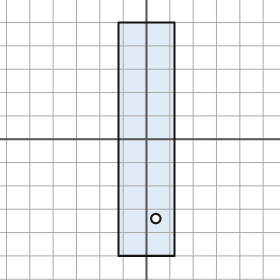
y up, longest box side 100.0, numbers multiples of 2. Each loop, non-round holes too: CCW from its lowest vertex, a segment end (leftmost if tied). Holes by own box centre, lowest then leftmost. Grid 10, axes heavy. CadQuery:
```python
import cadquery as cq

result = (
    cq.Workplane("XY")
    .moveTo(-12.0, -50.0)
    .lineTo(12.0, -50.0)
    .lineTo(12.0, 50.0)
    .lineTo(-12.0, 50.0)
    .close()
    .moveTo(4.0, -34.0)
    .circle(2.0)
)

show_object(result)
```